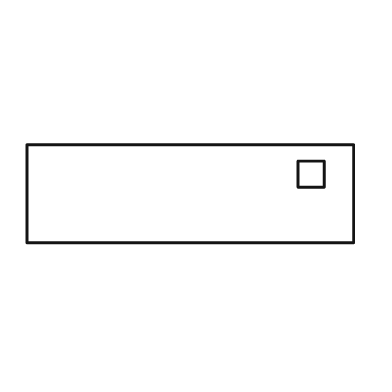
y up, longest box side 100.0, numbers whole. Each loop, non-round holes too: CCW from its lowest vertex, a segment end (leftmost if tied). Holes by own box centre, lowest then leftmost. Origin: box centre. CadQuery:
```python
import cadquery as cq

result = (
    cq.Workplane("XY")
    .moveTo(-50.0, -15.0)
    .lineTo(50.0, -15.0)
    .lineTo(50.0, 15.0)
    .lineTo(-50.0, 15.0)
    .close()
    .moveTo(33.0, 2.0)
    .lineTo(41.0, 2.0)
    .lineTo(41.0, 10.0)
    .lineTo(33.0, 10.0)
    .close()
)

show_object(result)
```